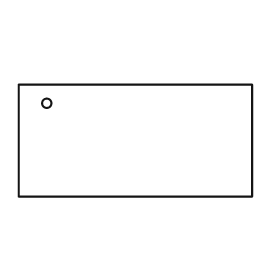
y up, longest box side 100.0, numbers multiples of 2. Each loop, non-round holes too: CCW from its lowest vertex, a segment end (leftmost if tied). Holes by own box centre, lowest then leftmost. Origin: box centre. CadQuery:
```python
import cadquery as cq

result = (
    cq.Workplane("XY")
    .moveTo(-50.0, -24.0)
    .lineTo(50.0, -24.0)
    .lineTo(50.0, 24.0)
    .lineTo(-50.0, 24.0)
    .close()
    .moveTo(-38.0, 16.0)
    .circle(2.0)
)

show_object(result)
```